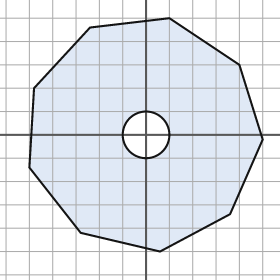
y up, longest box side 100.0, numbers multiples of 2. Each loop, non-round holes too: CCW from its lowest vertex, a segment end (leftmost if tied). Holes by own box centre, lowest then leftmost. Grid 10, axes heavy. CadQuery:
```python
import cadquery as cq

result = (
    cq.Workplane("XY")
    .moveTo(6.0, -50.0)
    .lineTo(36.0, -34.0)
    .lineTo(50.0, -2.0)
    .lineTo(40.0, 30.0)
    .lineTo(10.0, 50.0)
    .lineTo(-24.0, 46.0)
    .lineTo(-48.0, 20.0)
    .lineTo(-50.0, -14.0)
    .lineTo(-28.0, -42.0)
    .close()
    .moveTo(0.0, 0.0)
    .circle(10.0)
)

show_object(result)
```